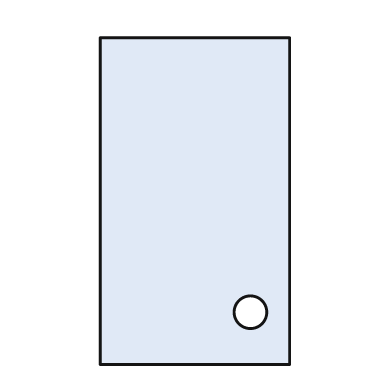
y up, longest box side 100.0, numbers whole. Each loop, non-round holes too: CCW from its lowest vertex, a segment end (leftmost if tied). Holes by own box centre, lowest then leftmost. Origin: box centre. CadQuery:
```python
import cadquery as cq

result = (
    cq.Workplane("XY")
    .moveTo(-29.0, -50.0)
    .lineTo(29.0, -50.0)
    .lineTo(29.0, 50.0)
    .lineTo(-29.0, 50.0)
    .close()
    .moveTo(17.0, -34.0)
    .circle(5.0)
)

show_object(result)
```